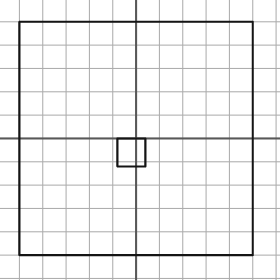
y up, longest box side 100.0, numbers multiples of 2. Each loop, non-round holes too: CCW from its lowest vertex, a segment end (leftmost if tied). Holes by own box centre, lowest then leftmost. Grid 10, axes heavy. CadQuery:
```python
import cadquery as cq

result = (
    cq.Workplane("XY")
    .moveTo(-50.0, -50.0)
    .lineTo(50.0, -50.0)
    .lineTo(50.0, 50.0)
    .lineTo(-50.0, 50.0)
    .close()
    .moveTo(-8.0, -12.0)
    .lineTo(4.0, -12.0)
    .lineTo(4.0, 0.0)
    .lineTo(-8.0, 0.0)
    .close()
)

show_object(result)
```